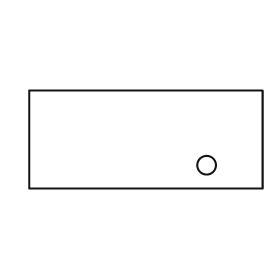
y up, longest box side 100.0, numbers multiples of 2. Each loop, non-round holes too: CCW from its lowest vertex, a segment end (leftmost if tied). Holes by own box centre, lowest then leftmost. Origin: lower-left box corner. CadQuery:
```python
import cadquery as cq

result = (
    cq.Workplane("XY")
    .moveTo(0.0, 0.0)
    .lineTo(100.0, 0.0)
    .lineTo(100.0, 42.0)
    .lineTo(0.0, 42.0)
    .close()
    .moveTo(76.0, 10.0)
    .circle(4.0)
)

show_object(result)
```